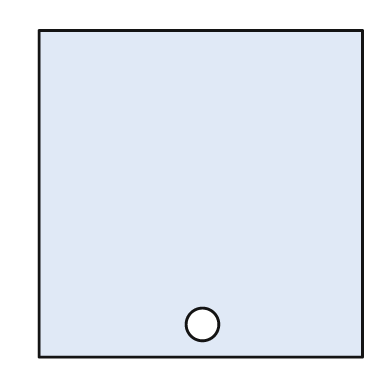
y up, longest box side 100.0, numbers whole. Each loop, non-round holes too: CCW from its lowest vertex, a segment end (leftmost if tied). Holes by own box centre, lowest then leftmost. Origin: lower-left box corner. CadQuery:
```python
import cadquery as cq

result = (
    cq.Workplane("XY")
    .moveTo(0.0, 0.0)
    .lineTo(99.0, 0.0)
    .lineTo(99.0, 100.0)
    .lineTo(0.0, 100.0)
    .close()
    .moveTo(50.0, 10.0)
    .circle(5.0)
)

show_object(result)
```